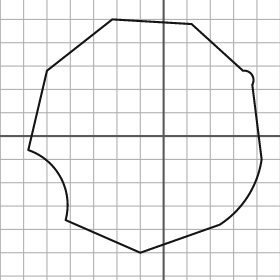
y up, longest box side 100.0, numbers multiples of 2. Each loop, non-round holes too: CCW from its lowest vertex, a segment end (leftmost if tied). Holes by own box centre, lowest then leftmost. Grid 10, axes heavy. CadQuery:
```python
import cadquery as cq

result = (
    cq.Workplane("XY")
    .moveTo(-10.0, -50.0)
    .lineTo(24.0, -38.0)
    .threePointArc((36.0, -26.0), (42.0, -10.0))
    .lineTo(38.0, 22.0)
    .threePointArc((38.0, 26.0), (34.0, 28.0))
    .lineTo(12.0, 48.0)
    .lineTo(-22.0, 50.0)
    .lineTo(-50.0, 28.0)
    .lineTo(-58.0, -6.0)
    .threePointArc((-44.0, -18.0), (-42.0, -36.0))
    .close()
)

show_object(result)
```